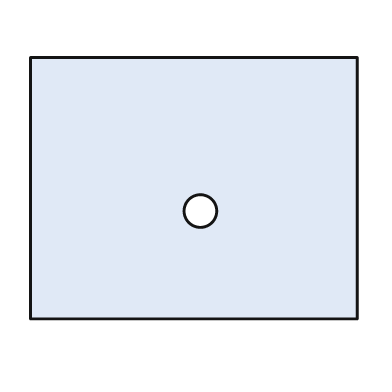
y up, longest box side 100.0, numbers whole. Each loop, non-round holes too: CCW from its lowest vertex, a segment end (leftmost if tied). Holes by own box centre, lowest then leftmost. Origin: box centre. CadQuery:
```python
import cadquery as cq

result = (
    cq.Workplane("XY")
    .moveTo(-50.0, -40.0)
    .lineTo(50.0, -40.0)
    .lineTo(50.0, 40.0)
    .lineTo(-50.0, 40.0)
    .close()
    .moveTo(2.0, -7.0)
    .circle(5.0)
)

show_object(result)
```